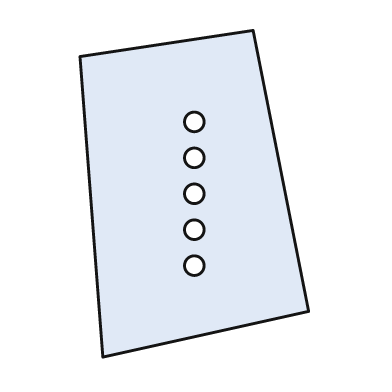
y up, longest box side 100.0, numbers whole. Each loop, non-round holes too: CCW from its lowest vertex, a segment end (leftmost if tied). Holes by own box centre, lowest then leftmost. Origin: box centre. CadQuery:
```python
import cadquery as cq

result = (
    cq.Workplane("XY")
    .moveTo(-28.0, -50.0)
    .lineTo(35.0, -36.0)
    .lineTo(18.0, 50.0)
    .lineTo(-35.0, 42.0)
    .close()
    .moveTo(0.0, -22.0)
    .circle(3.0)
    .moveTo(0.0, -11.0)
    .circle(3.0)
    .moveTo(0.0, 0.0)
    .circle(3.0)
    .moveTo(0.0, 11.0)
    .circle(3.0)
    .moveTo(0.0, 22.0)
    .circle(3.0)
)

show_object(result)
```